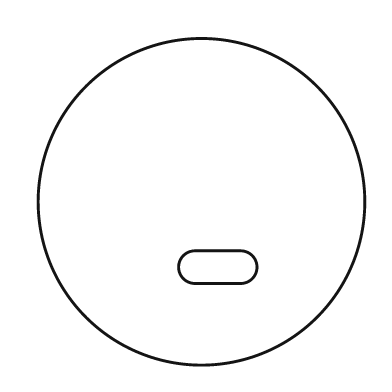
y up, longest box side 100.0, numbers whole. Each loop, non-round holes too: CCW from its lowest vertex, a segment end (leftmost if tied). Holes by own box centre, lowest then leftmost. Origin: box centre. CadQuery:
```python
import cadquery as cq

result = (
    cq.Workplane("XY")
    .moveTo(0.0, 0.0)
    .circle(50.0)
    .moveTo(-2.0, -25.0)
    .lineTo(12.0, -25.0)
    .threePointArc((17.0, -20.0), (12.0, -15.0))
    .lineTo(-2.0, -15.0)
    .threePointArc((-7.0, -20.0), (-2.0, -25.0))
    .close()
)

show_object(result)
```